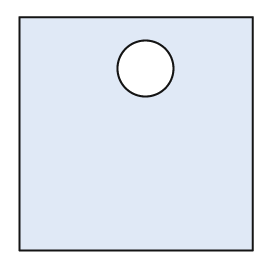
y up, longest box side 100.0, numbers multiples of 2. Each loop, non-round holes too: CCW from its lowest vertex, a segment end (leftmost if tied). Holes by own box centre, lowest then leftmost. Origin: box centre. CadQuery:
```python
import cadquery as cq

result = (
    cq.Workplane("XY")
    .moveTo(-50.0, -50.0)
    .lineTo(50.0, -50.0)
    .lineTo(50.0, 50.0)
    .lineTo(-50.0, 50.0)
    .close()
    .moveTo(4.0, 28.0)
    .circle(12.0)
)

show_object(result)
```